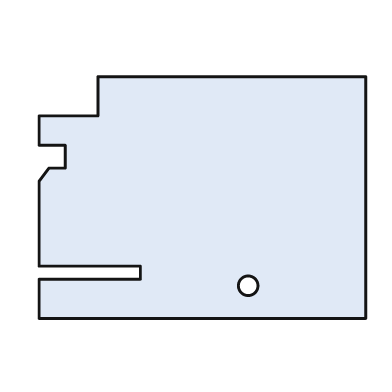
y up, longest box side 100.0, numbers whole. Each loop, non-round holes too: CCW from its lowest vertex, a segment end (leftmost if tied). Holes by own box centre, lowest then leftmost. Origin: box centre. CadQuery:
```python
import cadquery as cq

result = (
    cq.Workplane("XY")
    .moveTo(-50.0, -37.0)
    .lineTo(50.0, -37.0)
    .lineTo(50.0, 37.0)
    .lineTo(-32.0, 37.0)
    .lineTo(-32.0, 25.0)
    .lineTo(-50.0, 25.0)
    .lineTo(-50.0, 16.0)
    .lineTo(-42.0, 16.0)
    .lineTo(-42.0, 9.0)
    .lineTo(-47.0, 9.0)
    .lineTo(-50.0, 5.0)
    .lineTo(-50.0, -21.0)
    .lineTo(-19.0, -21.0)
    .lineTo(-19.0, -25.0)
    .lineTo(-50.0, -25.0)
    .close()
    .moveTo(14.0, -27.0)
    .circle(3.0)
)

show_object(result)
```